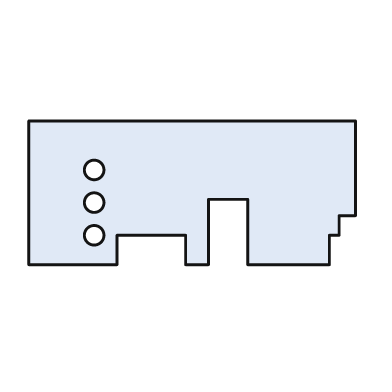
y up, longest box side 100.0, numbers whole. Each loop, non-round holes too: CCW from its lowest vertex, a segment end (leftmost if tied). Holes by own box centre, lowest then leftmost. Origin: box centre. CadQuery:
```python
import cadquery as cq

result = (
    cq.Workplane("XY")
    .moveTo(-50.0, -22.0)
    .lineTo(-23.0, -22.0)
    .lineTo(-23.0, -13.0)
    .lineTo(-2.0, -13.0)
    .lineTo(-2.0, -22.0)
    .lineTo(5.0, -22.0)
    .lineTo(5.0, -2.0)
    .lineTo(17.0, -2.0)
    .lineTo(17.0, -22.0)
    .lineTo(42.0, -22.0)
    .lineTo(42.0, -13.0)
    .lineTo(45.0, -13.0)
    .lineTo(45.0, -7.0)
    .lineTo(50.0, -7.0)
    .lineTo(50.0, 22.0)
    .lineTo(-50.0, 22.0)
    .close()
    .moveTo(-30.0, -13.0)
    .circle(3.0)
    .moveTo(-30.0, -3.0)
    .circle(3.0)
    .moveTo(-30.0, 7.0)
    .circle(3.0)
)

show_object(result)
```